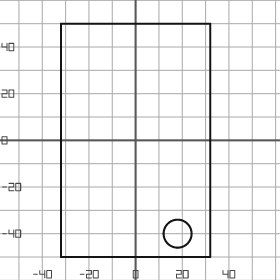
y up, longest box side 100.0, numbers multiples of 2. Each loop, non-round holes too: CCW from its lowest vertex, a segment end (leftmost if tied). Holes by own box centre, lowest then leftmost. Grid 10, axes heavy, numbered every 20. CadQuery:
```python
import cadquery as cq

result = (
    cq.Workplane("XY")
    .moveTo(-32.0, -50.0)
    .lineTo(32.0, -50.0)
    .lineTo(32.0, 50.0)
    .lineTo(-32.0, 50.0)
    .close()
    .moveTo(18.0, -40.0)
    .circle(6.0)
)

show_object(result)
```